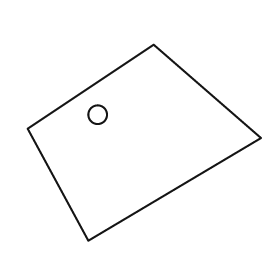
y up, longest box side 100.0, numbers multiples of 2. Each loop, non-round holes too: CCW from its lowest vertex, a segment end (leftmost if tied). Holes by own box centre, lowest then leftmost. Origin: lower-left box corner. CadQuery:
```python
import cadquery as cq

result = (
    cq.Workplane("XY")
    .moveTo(26.0, 0.0)
    .lineTo(100.0, 44.0)
    .lineTo(54.0, 84.0)
    .lineTo(0.0, 48.0)
    .close()
    .moveTo(30.0, 54.0)
    .circle(4.0)
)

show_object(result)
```